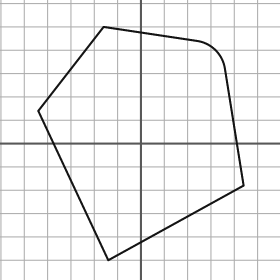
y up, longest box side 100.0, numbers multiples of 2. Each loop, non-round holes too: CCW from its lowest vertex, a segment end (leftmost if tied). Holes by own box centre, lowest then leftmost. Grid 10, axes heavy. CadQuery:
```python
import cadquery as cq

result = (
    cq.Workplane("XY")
    .moveTo(-14.0, -50.0)
    .lineTo(44.0, -18.0)
    .lineTo(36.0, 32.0)
    .threePointArc((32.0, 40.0), (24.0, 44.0))
    .lineTo(-16.0, 50.0)
    .lineTo(-44.0, 14.0)
    .close()
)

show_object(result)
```